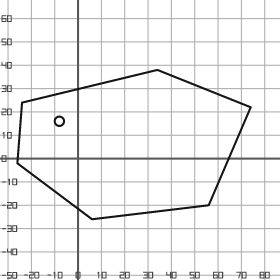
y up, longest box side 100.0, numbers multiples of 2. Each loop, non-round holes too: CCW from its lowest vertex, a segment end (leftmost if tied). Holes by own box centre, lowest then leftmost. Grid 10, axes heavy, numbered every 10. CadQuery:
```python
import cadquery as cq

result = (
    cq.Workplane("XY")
    .moveTo(6.0, -26.0)
    .lineTo(56.0, -20.0)
    .lineTo(74.0, 22.0)
    .lineTo(34.0, 38.0)
    .lineTo(-24.0, 24.0)
    .lineTo(-26.0, -2.0)
    .close()
    .moveTo(-8.0, 16.0)
    .circle(2.0)
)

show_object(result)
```